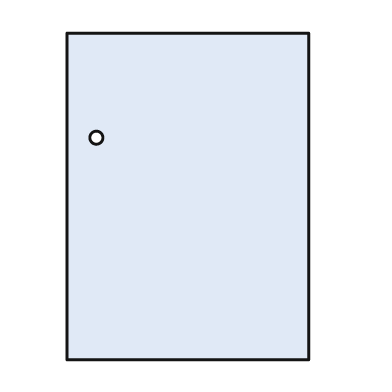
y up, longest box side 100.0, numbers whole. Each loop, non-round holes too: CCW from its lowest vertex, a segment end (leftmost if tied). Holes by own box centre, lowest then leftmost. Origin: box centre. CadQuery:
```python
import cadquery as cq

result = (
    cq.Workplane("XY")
    .moveTo(-37.0, -50.0)
    .lineTo(37.0, -50.0)
    .lineTo(37.0, 50.0)
    .lineTo(-37.0, 50.0)
    .close()
    .moveTo(-28.0, 18.0)
    .circle(2.0)
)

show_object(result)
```